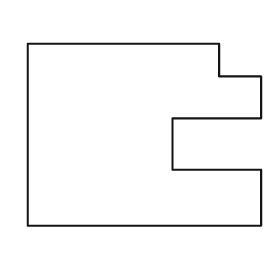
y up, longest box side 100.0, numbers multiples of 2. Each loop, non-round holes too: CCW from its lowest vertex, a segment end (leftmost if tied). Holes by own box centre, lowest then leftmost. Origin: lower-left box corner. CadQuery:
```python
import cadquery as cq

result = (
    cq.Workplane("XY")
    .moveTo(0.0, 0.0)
    .lineTo(100.0, 0.0)
    .lineTo(100.0, 24.0)
    .lineTo(62.0, 24.0)
    .lineTo(62.0, 46.0)
    .lineTo(100.0, 46.0)
    .lineTo(100.0, 64.0)
    .lineTo(82.0, 64.0)
    .lineTo(82.0, 78.0)
    .lineTo(0.0, 78.0)
    .close()
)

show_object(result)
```